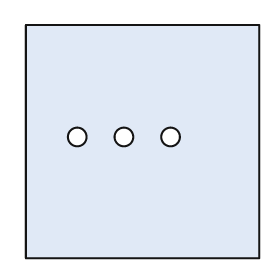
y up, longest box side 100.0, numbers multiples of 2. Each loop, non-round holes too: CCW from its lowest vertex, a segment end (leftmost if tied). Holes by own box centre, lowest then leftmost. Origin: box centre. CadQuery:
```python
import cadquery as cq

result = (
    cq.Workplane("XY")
    .moveTo(-50.0, -50.0)
    .lineTo(50.0, -50.0)
    .lineTo(50.0, 50.0)
    .lineTo(-50.0, 50.0)
    .close()
    .moveTo(-28.0, 2.0)
    .circle(4.0)
    .moveTo(-8.0, 2.0)
    .circle(4.0)
    .moveTo(12.0, 2.0)
    .circle(4.0)
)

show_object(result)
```